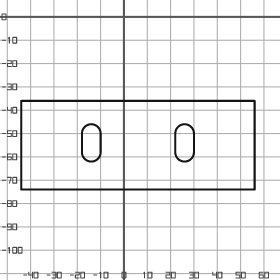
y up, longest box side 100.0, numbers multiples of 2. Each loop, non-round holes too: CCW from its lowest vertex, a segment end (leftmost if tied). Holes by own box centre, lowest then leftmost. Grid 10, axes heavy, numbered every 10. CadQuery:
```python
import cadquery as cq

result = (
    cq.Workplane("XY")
    .moveTo(-44.0, -74.0)
    .lineTo(56.0, -74.0)
    .lineTo(56.0, -36.0)
    .lineTo(-44.0, -36.0)
    .close()
    .moveTo(-18.0, -58.0)
    .threePointArc((-14.0, -62.0), (-10.0, -58.0))
    .lineTo(-10.0, -50.0)
    .threePointArc((-14.0, -46.0), (-18.0, -50.0))
    .close()
    .moveTo(22.0, -58.0)
    .threePointArc((26.0, -62.0), (30.0, -58.0))
    .lineTo(30.0, -50.0)
    .threePointArc((26.0, -46.0), (22.0, -50.0))
    .close()
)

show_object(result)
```